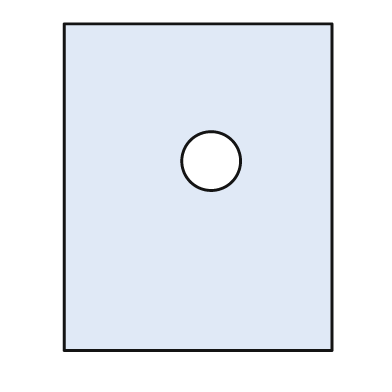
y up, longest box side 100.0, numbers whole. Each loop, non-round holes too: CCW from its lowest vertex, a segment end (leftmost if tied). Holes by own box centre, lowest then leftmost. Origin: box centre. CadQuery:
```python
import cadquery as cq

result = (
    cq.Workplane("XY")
    .moveTo(-41.0, -50.0)
    .lineTo(41.0, -50.0)
    .lineTo(41.0, 50.0)
    .lineTo(-41.0, 50.0)
    .close()
    .moveTo(4.0, 8.0)
    .circle(9.0)
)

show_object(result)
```